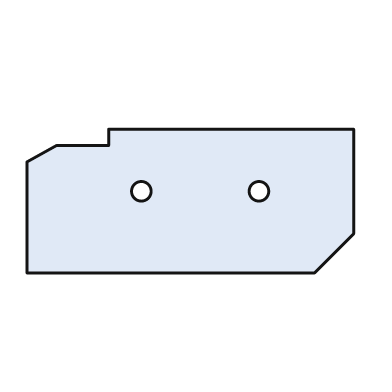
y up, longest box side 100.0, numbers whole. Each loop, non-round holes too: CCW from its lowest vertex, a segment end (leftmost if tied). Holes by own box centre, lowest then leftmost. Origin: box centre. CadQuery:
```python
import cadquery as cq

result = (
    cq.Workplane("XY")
    .moveTo(-50.0, -22.0)
    .lineTo(38.0, -22.0)
    .lineTo(50.0, -10.0)
    .lineTo(50.0, 22.0)
    .lineTo(-25.0, 22.0)
    .lineTo(-25.0, 17.0)
    .lineTo(-41.0, 17.0)
    .lineTo(-50.0, 12.0)
    .close()
    .moveTo(-15.0, 3.0)
    .circle(3.0)
    .moveTo(21.0, 3.0)
    .circle(3.0)
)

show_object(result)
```